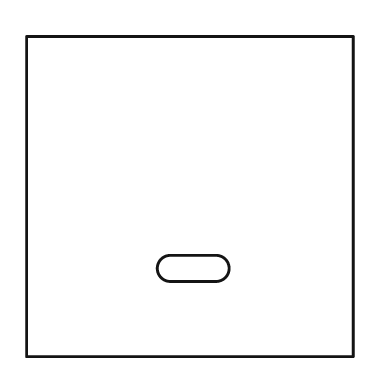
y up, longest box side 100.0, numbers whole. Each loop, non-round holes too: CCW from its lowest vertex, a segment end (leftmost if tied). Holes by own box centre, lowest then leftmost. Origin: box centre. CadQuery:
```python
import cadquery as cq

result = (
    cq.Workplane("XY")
    .moveTo(-50.0, -49.0)
    .lineTo(50.0, -49.0)
    .lineTo(50.0, 49.0)
    .lineTo(-50.0, 49.0)
    .close()
    .moveTo(-6.0, -26.0)
    .lineTo(8.0, -26.0)
    .threePointArc((12.0, -22.0), (8.0, -18.0))
    .lineTo(-6.0, -18.0)
    .threePointArc((-10.0, -22.0), (-6.0, -26.0))
    .close()
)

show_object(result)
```